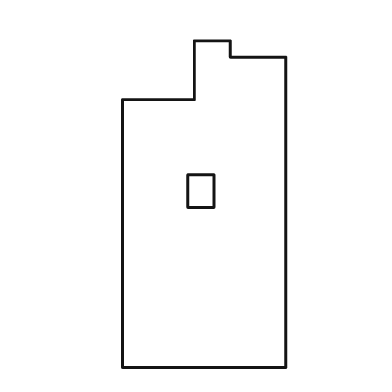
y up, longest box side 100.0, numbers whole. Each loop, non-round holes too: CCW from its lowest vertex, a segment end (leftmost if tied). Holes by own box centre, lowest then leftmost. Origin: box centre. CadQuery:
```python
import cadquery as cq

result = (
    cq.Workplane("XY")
    .moveTo(-25.0, -50.0)
    .lineTo(25.0, -50.0)
    .lineTo(25.0, 45.0)
    .lineTo(8.0, 45.0)
    .lineTo(8.0, 50.0)
    .lineTo(-3.0, 50.0)
    .lineTo(-3.0, 32.0)
    .lineTo(-25.0, 32.0)
    .close()
    .moveTo(-5.0, -1.0)
    .lineTo(3.0, -1.0)
    .lineTo(3.0, 9.0)
    .lineTo(-5.0, 9.0)
    .close()
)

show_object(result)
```